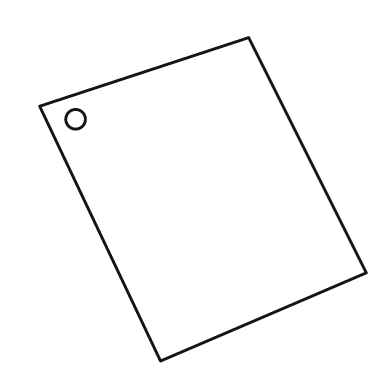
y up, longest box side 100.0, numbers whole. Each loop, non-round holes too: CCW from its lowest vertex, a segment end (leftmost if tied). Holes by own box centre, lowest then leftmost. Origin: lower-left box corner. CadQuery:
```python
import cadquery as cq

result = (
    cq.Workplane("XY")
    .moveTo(37.0, 0.0)
    .lineTo(100.0, 27.0)
    .lineTo(64.0, 99.0)
    .lineTo(0.0, 78.0)
    .close()
    .moveTo(11.0, 74.0)
    .circle(3.0)
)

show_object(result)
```